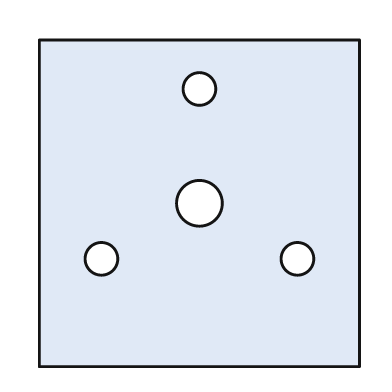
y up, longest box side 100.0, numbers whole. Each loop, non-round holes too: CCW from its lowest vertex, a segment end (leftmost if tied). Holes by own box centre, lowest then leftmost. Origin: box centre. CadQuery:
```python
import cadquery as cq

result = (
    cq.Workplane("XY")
    .moveTo(-49.0, -50.0)
    .lineTo(49.0, -50.0)
    .lineTo(49.0, 50.0)
    .lineTo(-49.0, 50.0)
    .close()
    .moveTo(-30.0, -17.0)
    .circle(5.0)
    .moveTo(30.0, -17.0)
    .circle(5.0)
    .moveTo(0.0, 0.0)
    .circle(7.0)
    .moveTo(0.0, 35.0)
    .circle(5.0)
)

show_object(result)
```